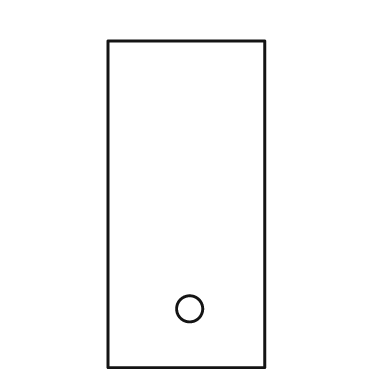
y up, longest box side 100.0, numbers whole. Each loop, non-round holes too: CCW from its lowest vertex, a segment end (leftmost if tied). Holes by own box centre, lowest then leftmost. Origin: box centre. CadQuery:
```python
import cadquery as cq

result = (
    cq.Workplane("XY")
    .moveTo(-24.0, -50.0)
    .lineTo(24.0, -50.0)
    .lineTo(24.0, 50.0)
    .lineTo(-24.0, 50.0)
    .close()
    .moveTo(1.0, -32.0)
    .circle(4.0)
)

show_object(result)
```